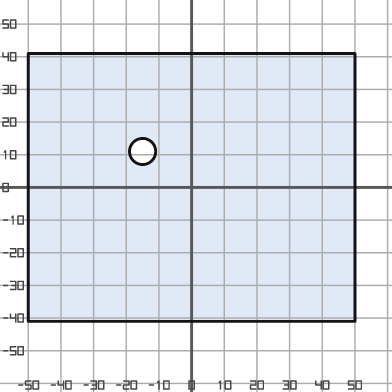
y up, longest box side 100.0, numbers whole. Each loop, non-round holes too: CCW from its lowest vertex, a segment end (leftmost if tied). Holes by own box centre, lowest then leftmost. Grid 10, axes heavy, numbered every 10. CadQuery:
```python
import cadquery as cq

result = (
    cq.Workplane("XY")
    .moveTo(-50.0, -41.0)
    .lineTo(50.0, -41.0)
    .lineTo(50.0, 41.0)
    .lineTo(-50.0, 41.0)
    .close()
    .moveTo(-15.0, 11.0)
    .circle(4.0)
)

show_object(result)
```